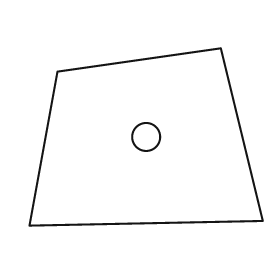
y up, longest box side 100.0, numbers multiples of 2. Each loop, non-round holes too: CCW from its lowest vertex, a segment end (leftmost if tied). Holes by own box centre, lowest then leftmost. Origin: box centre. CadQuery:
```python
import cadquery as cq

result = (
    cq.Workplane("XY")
    .moveTo(-50.0, -38.0)
    .lineTo(50.0, -36.0)
    .lineTo(32.0, 38.0)
    .lineTo(-38.0, 28.0)
    .close()
    .moveTo(0.0, 0.0)
    .circle(6.0)
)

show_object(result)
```